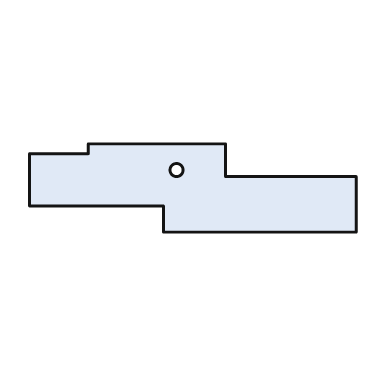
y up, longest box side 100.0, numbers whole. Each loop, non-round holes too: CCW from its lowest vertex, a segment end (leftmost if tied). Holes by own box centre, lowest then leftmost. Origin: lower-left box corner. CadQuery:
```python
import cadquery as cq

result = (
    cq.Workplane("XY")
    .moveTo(41.0, 0.0)
    .lineTo(100.0, 0.0)
    .lineTo(100.0, 17.0)
    .lineTo(60.0, 17.0)
    .lineTo(60.0, 27.0)
    .lineTo(18.0, 27.0)
    .lineTo(18.0, 24.0)
    .lineTo(0.0, 24.0)
    .lineTo(0.0, 8.0)
    .lineTo(41.0, 8.0)
    .close()
    .moveTo(45.0, 19.0)
    .circle(2.0)
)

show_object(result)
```